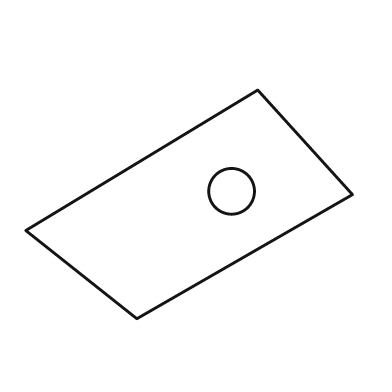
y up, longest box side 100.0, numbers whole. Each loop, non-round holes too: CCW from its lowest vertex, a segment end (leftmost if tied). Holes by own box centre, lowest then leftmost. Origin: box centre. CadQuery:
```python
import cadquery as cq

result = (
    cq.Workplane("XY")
    .moveTo(-16.0, -35.0)
    .lineTo(50.0, 3.0)
    .lineTo(21.0, 35.0)
    .lineTo(-50.0, -8.0)
    .close()
    .moveTo(13.0, 4.0)
    .circle(7.0)
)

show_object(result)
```